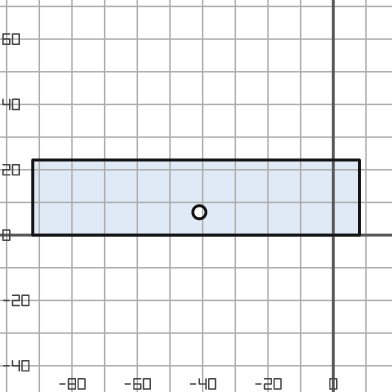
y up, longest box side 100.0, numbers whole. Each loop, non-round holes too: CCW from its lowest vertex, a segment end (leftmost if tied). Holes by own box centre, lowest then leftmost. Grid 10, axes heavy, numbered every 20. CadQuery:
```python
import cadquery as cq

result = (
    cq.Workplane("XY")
    .moveTo(-92.0, 0.0)
    .lineTo(8.0, 0.0)
    .lineTo(8.0, 23.0)
    .lineTo(-92.0, 23.0)
    .close()
    .moveTo(-41.0, 7.0)
    .circle(2.0)
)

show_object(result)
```